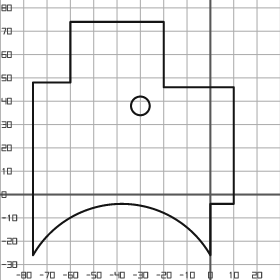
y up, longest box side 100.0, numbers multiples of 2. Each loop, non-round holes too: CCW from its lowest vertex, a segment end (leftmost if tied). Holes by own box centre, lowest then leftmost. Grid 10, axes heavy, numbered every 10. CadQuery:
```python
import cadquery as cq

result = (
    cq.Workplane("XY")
    .moveTo(-76.0, -26.0)
    .threePointArc((-38.0, -4.0), (0.0, -26.0))
    .lineTo(0.0, -4.0)
    .lineTo(10.0, -4.0)
    .lineTo(10.0, 46.0)
    .lineTo(-20.0, 46.0)
    .lineTo(-20.0, 74.0)
    .lineTo(-60.0, 74.0)
    .lineTo(-60.0, 48.0)
    .lineTo(-76.0, 48.0)
    .close()
    .moveTo(-30.0, 38.0)
    .circle(4.0)
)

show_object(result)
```